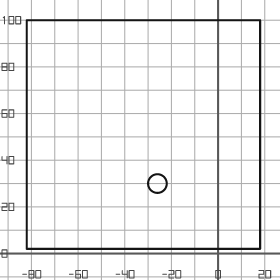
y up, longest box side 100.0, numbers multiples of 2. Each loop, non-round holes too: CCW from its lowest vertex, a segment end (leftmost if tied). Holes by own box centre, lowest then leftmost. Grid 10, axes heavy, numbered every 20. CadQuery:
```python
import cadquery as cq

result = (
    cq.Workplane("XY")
    .moveTo(-82.0, 2.0)
    .lineTo(18.0, 2.0)
    .lineTo(18.0, 100.0)
    .lineTo(-82.0, 100.0)
    .close()
    .moveTo(-26.0, 30.0)
    .circle(4.0)
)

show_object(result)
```